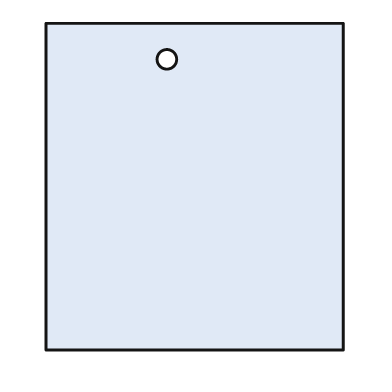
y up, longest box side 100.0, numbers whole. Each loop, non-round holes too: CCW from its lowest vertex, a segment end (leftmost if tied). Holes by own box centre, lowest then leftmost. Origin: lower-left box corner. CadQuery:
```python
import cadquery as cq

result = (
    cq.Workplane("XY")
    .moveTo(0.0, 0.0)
    .lineTo(91.0, 0.0)
    .lineTo(91.0, 100.0)
    .lineTo(0.0, 100.0)
    .close()
    .moveTo(37.0, 89.0)
    .circle(3.0)
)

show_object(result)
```